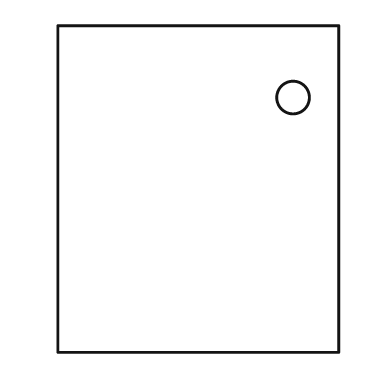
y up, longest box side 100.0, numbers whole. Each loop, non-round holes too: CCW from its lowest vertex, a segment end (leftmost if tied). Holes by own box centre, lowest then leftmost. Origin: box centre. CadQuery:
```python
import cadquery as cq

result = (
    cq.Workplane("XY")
    .moveTo(-43.0, -50.0)
    .lineTo(43.0, -50.0)
    .lineTo(43.0, 50.0)
    .lineTo(-43.0, 50.0)
    .close()
    .moveTo(29.0, 28.0)
    .circle(5.0)
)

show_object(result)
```